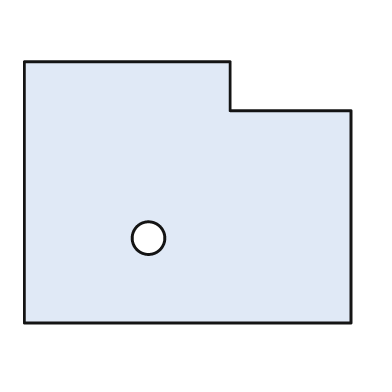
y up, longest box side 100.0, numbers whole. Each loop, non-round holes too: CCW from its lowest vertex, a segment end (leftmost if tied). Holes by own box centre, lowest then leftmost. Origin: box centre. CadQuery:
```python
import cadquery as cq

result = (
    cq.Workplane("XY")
    .moveTo(-50.0, -40.0)
    .lineTo(50.0, -40.0)
    .lineTo(50.0, 25.0)
    .lineTo(13.0, 25.0)
    .lineTo(13.0, 40.0)
    .lineTo(-50.0, 40.0)
    .close()
    .moveTo(-12.0, -14.0)
    .circle(5.0)
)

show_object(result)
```